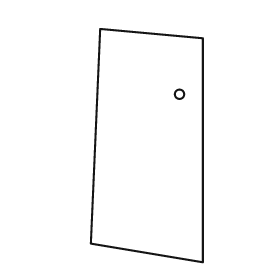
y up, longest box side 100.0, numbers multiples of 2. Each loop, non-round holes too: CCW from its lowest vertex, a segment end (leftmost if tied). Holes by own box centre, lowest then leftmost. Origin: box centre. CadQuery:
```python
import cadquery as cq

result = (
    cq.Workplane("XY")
    .moveTo(24.0, -50.0)
    .lineTo(24.0, 46.0)
    .lineTo(-20.0, 50.0)
    .lineTo(-24.0, -42.0)
    .close()
    .moveTo(14.0, 22.0)
    .circle(2.0)
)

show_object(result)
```